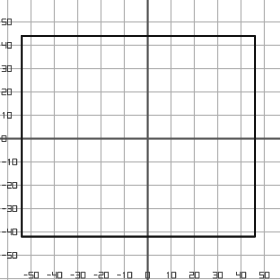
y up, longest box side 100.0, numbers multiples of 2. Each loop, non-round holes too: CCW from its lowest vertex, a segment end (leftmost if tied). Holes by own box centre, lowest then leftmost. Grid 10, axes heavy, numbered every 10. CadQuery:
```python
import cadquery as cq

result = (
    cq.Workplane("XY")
    .moveTo(-54.0, -42.0)
    .lineTo(46.0, -42.0)
    .lineTo(46.0, 44.0)
    .lineTo(-54.0, 44.0)
    .close()
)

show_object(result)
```